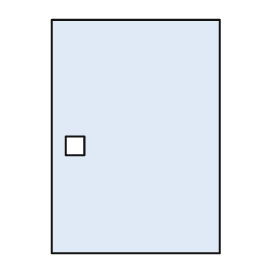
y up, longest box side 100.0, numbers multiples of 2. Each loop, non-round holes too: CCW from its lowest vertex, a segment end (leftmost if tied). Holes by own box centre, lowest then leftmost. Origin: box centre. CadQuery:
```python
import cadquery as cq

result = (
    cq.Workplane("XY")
    .moveTo(-36.0, -50.0)
    .lineTo(36.0, -50.0)
    .lineTo(36.0, 50.0)
    .lineTo(-36.0, 50.0)
    .close()
    .moveTo(-30.0, -8.0)
    .lineTo(-22.0, -8.0)
    .lineTo(-22.0, 0.0)
    .lineTo(-30.0, 0.0)
    .close()
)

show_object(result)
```